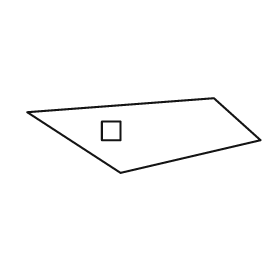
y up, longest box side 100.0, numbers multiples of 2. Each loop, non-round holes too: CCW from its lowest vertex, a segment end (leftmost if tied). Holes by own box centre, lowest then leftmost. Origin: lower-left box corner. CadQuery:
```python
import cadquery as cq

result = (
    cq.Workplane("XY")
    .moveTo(40.0, 0.0)
    .lineTo(100.0, 14.0)
    .lineTo(80.0, 32.0)
    .lineTo(0.0, 26.0)
    .close()
    .moveTo(32.0, 14.0)
    .lineTo(40.0, 14.0)
    .lineTo(40.0, 22.0)
    .lineTo(32.0, 22.0)
    .close()
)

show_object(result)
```